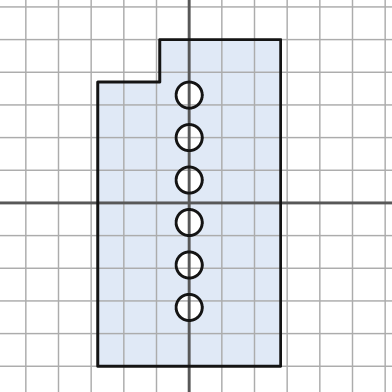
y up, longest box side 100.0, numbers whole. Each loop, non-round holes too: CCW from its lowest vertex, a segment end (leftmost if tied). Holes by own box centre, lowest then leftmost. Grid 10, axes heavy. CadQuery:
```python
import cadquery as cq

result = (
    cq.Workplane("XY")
    .moveTo(-28.0, -50.0)
    .lineTo(28.0, -50.0)
    .lineTo(28.0, 50.0)
    .lineTo(-9.0, 50.0)
    .lineTo(-9.0, 37.0)
    .lineTo(-28.0, 37.0)
    .close()
    .moveTo(0.0, -32.0)
    .circle(4.0)
    .moveTo(0.0, -19.0)
    .circle(4.0)
    .moveTo(0.0, -6.0)
    .circle(4.0)
    .moveTo(0.0, 7.0)
    .circle(4.0)
    .moveTo(0.0, 20.0)
    .circle(4.0)
    .moveTo(0.0, 33.0)
    .circle(4.0)
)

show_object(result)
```